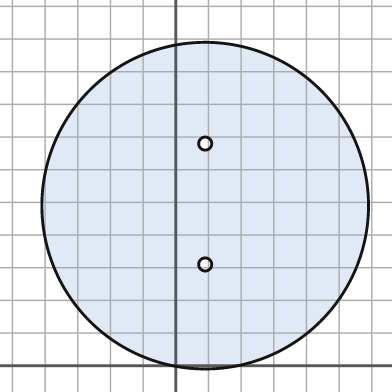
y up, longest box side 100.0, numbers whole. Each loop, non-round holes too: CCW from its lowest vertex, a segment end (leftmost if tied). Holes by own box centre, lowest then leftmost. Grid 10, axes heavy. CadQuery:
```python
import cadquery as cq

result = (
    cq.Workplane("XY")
    .moveTo(9.0, 49.0)
    .circle(50.0)
    .moveTo(9.0, 31.0)
    .circle(2.0)
    .moveTo(9.0, 68.0)
    .circle(2.0)
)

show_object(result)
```